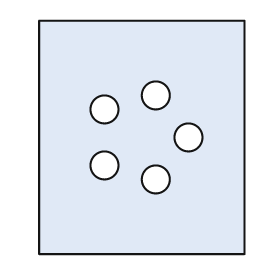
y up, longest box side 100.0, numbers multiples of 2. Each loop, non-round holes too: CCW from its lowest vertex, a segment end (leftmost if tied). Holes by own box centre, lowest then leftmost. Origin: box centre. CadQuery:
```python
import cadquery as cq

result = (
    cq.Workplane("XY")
    .moveTo(-44.0, -50.0)
    .lineTo(44.0, -50.0)
    .lineTo(44.0, 50.0)
    .lineTo(-44.0, 50.0)
    .close()
    .moveTo(6.0, -18.0)
    .circle(6.0)
    .moveTo(-16.0, -12.0)
    .circle(6.0)
    .moveTo(20.0, 0.0)
    .circle(6.0)
    .moveTo(-16.0, 12.0)
    .circle(6.0)
    .moveTo(6.0, 18.0)
    .circle(6.0)
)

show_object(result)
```